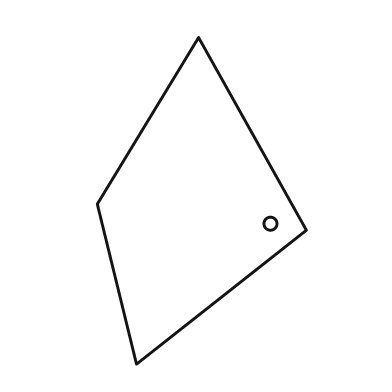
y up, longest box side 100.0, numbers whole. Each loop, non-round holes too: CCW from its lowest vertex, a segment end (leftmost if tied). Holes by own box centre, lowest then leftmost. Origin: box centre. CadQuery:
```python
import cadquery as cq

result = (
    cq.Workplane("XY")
    .moveTo(-20.0, -50.0)
    .lineTo(32.0, -9.0)
    .lineTo(-1.0, 50.0)
    .lineTo(-32.0, -1.0)
    .close()
    .moveTo(21.0, -7.0)
    .circle(2.0)
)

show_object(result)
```